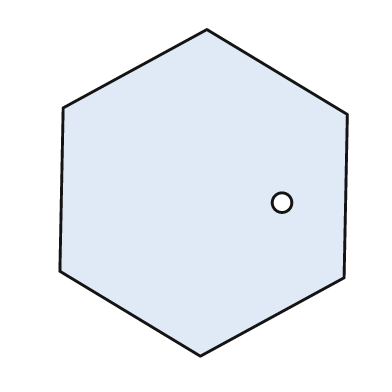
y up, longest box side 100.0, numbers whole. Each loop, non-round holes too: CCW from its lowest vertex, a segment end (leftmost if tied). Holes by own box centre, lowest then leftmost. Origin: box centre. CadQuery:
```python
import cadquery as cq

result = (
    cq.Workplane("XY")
    .moveTo(-1.0, -50.0)
    .lineTo(43.0, -26.0)
    .lineTo(44.0, 24.0)
    .lineTo(1.0, 50.0)
    .lineTo(-43.0, 26.0)
    .lineTo(-44.0, -24.0)
    .close()
    .moveTo(24.0, -3.0)
    .circle(3.0)
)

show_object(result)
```